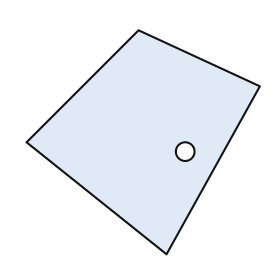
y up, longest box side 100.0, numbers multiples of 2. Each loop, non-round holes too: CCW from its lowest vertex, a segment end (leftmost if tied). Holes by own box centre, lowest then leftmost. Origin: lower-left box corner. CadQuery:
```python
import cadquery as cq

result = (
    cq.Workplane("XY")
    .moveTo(60.0, 0.0)
    .lineTo(100.0, 72.0)
    .lineTo(48.0, 96.0)
    .lineTo(0.0, 48.0)
    .close()
    .moveTo(68.0, 44.0)
    .circle(4.0)
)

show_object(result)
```